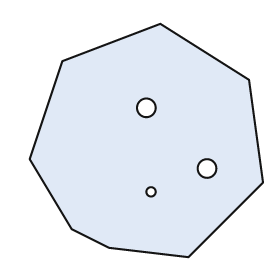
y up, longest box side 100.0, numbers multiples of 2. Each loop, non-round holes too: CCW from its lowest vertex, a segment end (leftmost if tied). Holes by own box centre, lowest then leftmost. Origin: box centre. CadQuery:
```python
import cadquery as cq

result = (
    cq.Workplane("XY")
    .moveTo(18.0, -50.0)
    .lineTo(50.0, -18.0)
    .lineTo(44.0, 26.0)
    .lineTo(6.0, 50.0)
    .lineTo(-36.0, 34.0)
    .lineTo(-50.0, -8.0)
    .lineTo(-32.0, -38.0)
    .lineTo(-16.0, -46.0)
    .close()
    .moveTo(2.0, -22.0)
    .circle(2.0)
    .moveTo(26.0, -12.0)
    .circle(4.0)
    .moveTo(0.0, 14.0)
    .circle(4.0)
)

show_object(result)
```